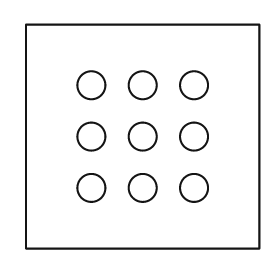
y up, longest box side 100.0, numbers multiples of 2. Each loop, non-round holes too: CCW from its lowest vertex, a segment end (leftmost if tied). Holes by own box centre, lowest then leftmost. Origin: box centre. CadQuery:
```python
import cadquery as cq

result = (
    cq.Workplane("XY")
    .moveTo(-50.0, -48.0)
    .lineTo(50.0, -48.0)
    .lineTo(50.0, 48.0)
    .lineTo(-50.0, 48.0)
    .close()
    .moveTo(-22.0, -22.0)
    .circle(6.0)
    .moveTo(0.0, -22.0)
    .circle(6.0)
    .moveTo(22.0, -22.0)
    .circle(6.0)
    .moveTo(-22.0, 0.0)
    .circle(6.0)
    .moveTo(0.0, 0.0)
    .circle(6.0)
    .moveTo(22.0, 0.0)
    .circle(6.0)
    .moveTo(-22.0, 22.0)
    .circle(6.0)
    .moveTo(0.0, 22.0)
    .circle(6.0)
    .moveTo(22.0, 22.0)
    .circle(6.0)
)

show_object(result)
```